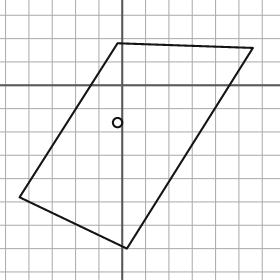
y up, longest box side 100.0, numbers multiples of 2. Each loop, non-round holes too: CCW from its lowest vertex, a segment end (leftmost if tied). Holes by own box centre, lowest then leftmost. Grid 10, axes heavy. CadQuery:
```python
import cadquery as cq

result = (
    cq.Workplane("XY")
    .moveTo(2.0, -70.0)
    .lineTo(56.0, 16.0)
    .lineTo(-2.0, 18.0)
    .lineTo(-44.0, -48.0)
    .close()
    .moveTo(-2.0, -16.0)
    .circle(2.0)
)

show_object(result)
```